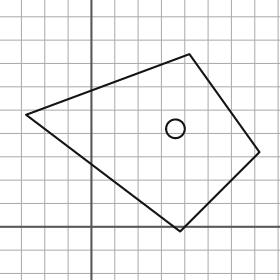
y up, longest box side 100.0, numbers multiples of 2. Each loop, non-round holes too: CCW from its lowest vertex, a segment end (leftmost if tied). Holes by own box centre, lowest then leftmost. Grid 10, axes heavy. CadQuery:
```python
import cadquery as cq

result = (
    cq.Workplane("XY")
    .moveTo(38.0, -2.0)
    .lineTo(72.0, 32.0)
    .lineTo(42.0, 74.0)
    .lineTo(-28.0, 48.0)
    .close()
    .moveTo(36.0, 42.0)
    .circle(4.0)
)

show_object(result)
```